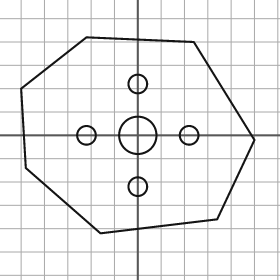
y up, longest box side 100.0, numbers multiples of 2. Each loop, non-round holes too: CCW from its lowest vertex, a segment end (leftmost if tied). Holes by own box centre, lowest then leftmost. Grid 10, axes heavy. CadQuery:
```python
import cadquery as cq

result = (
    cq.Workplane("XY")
    .moveTo(-16.0, -42.0)
    .lineTo(34.0, -36.0)
    .lineTo(50.0, -2.0)
    .lineTo(24.0, 40.0)
    .lineTo(-22.0, 42.0)
    .lineTo(-50.0, 20.0)
    .lineTo(-48.0, -14.0)
    .close()
    .moveTo(0.0, -22.0)
    .circle(4.0)
    .moveTo(-22.0, 0.0)
    .circle(4.0)
    .moveTo(0.0, 0.0)
    .circle(8.0)
    .moveTo(22.0, 0.0)
    .circle(4.0)
    .moveTo(0.0, 22.0)
    .circle(4.0)
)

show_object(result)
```